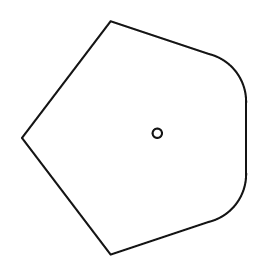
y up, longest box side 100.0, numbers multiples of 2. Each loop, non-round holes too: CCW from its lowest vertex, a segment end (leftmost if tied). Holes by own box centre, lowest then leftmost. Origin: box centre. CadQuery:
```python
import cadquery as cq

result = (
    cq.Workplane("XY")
    .moveTo(-10.0, -50.0)
    .lineTo(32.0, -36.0)
    .threePointArc((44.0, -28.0), (48.0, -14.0))
    .lineTo(48.0, 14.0)
    .threePointArc((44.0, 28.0), (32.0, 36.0))
    .lineTo(-10.0, 50.0)
    .lineTo(-48.0, 0.0)
    .close()
    .moveTo(10.0, 2.0)
    .circle(2.0)
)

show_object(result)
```